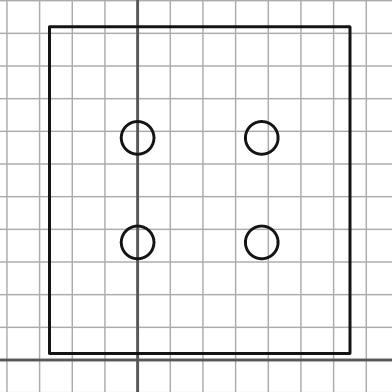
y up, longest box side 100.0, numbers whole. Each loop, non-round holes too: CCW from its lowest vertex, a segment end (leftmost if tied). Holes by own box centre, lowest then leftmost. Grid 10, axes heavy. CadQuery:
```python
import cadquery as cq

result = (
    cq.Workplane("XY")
    .moveTo(-27.0, 2.0)
    .lineTo(65.0, 2.0)
    .lineTo(65.0, 102.0)
    .lineTo(-27.0, 102.0)
    .close()
    .moveTo(0.0, 36.0)
    .circle(5.0)
    .moveTo(38.0, 36.0)
    .circle(5.0)
    .moveTo(0.0, 68.0)
    .circle(5.0)
    .moveTo(38.0, 68.0)
    .circle(5.0)
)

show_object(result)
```